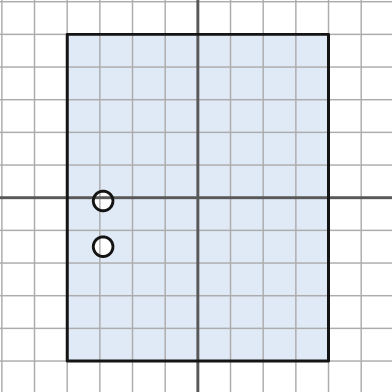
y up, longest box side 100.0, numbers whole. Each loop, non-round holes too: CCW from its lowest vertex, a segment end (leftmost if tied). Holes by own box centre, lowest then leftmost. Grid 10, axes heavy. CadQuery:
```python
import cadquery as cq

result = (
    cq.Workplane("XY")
    .moveTo(-40.0, -50.0)
    .lineTo(40.0, -50.0)
    .lineTo(40.0, 50.0)
    .lineTo(-40.0, 50.0)
    .close()
    .moveTo(-29.0, -15.0)
    .circle(3.0)
    .moveTo(-29.0, -1.0)
    .circle(3.0)
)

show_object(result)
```